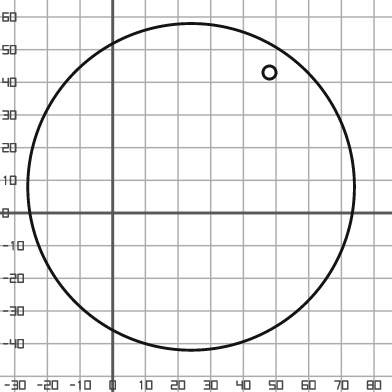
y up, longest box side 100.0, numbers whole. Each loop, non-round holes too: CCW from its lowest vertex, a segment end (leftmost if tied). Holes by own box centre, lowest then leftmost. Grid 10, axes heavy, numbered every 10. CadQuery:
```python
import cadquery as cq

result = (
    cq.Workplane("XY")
    .moveTo(24.0, 8.0)
    .circle(50.0)
    .moveTo(48.0, 43.0)
    .circle(2.0)
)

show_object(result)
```